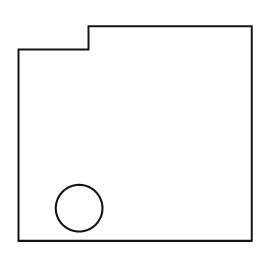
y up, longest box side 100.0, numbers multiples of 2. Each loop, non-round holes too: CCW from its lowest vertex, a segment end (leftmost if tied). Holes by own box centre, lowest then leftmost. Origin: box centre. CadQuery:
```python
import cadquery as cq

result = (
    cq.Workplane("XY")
    .moveTo(-50.0, -46.0)
    .lineTo(50.0, -46.0)
    .lineTo(50.0, 46.0)
    .lineTo(-20.0, 46.0)
    .lineTo(-20.0, 36.0)
    .lineTo(-50.0, 36.0)
    .close()
    .moveTo(-24.0, -32.0)
    .circle(10.0)
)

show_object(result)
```